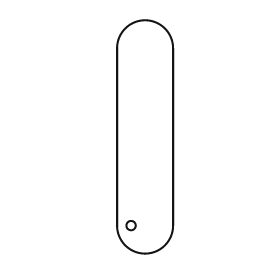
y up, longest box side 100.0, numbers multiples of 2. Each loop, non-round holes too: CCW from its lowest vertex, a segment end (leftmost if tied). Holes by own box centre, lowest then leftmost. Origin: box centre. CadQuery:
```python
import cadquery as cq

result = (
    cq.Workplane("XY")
    .moveTo(-12.0, -38.0)
    .threePointArc((0.0, -50.0), (12.0, -38.0))
    .lineTo(12.0, 38.0)
    .threePointArc((0.0, 50.0), (-12.0, 38.0))
    .close()
    .moveTo(-6.0, -38.0)
    .circle(2.0)
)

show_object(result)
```